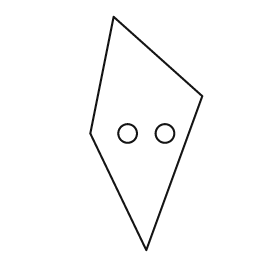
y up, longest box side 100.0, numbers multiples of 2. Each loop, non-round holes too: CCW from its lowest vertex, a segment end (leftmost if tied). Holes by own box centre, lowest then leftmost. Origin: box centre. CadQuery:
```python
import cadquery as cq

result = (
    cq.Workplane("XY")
    .moveTo(0.0, -50.0)
    .lineTo(24.0, 16.0)
    .lineTo(-14.0, 50.0)
    .lineTo(-24.0, 0.0)
    .close()
    .moveTo(-8.0, 0.0)
    .circle(4.0)
    .moveTo(8.0, 0.0)
    .circle(4.0)
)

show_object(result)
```